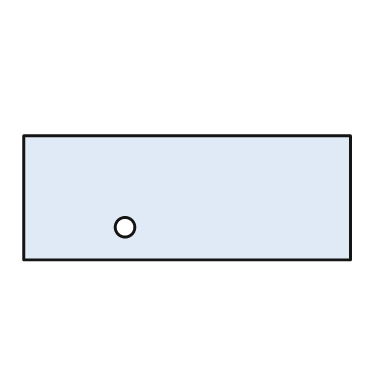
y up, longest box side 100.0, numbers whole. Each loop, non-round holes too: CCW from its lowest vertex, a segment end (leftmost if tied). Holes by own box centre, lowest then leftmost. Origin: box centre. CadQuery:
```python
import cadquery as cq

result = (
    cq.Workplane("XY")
    .moveTo(-50.0, -19.0)
    .lineTo(50.0, -19.0)
    .lineTo(50.0, 19.0)
    .lineTo(-50.0, 19.0)
    .close()
    .moveTo(-19.0, -9.0)
    .circle(3.0)
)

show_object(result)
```